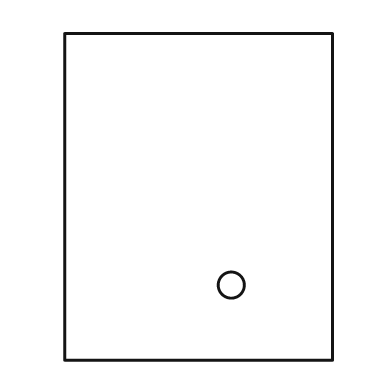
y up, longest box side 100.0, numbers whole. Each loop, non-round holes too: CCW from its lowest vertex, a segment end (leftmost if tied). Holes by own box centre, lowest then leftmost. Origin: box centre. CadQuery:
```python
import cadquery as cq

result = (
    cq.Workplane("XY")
    .moveTo(-41.0, -50.0)
    .lineTo(41.0, -50.0)
    .lineTo(41.0, 50.0)
    .lineTo(-41.0, 50.0)
    .close()
    .moveTo(10.0, -27.0)
    .circle(4.0)
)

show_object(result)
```